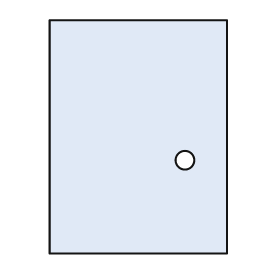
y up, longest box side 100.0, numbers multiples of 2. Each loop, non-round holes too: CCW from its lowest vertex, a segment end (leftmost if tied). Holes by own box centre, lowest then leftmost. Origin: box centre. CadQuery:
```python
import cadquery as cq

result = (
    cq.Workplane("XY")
    .moveTo(-38.0, -50.0)
    .lineTo(38.0, -50.0)
    .lineTo(38.0, 50.0)
    .lineTo(-38.0, 50.0)
    .close()
    .moveTo(20.0, -10.0)
    .circle(4.0)
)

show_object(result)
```